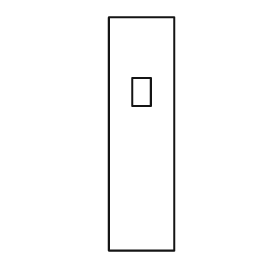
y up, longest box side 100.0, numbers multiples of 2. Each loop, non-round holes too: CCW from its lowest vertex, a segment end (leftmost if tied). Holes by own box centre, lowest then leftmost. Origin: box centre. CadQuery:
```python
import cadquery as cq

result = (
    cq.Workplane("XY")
    .moveTo(-14.0, -50.0)
    .lineTo(14.0, -50.0)
    .lineTo(14.0, 50.0)
    .lineTo(-14.0, 50.0)
    .close()
    .moveTo(-4.0, 12.0)
    .lineTo(4.0, 12.0)
    .lineTo(4.0, 24.0)
    .lineTo(-4.0, 24.0)
    .close()
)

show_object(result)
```